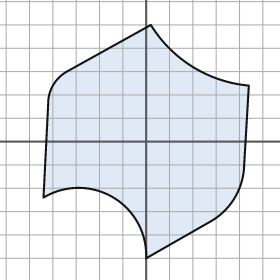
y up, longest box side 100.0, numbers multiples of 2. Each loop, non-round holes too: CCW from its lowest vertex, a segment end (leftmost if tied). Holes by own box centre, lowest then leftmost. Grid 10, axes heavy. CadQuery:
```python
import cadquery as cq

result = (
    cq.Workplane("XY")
    .moveTo(0.0, -50.0)
    .lineTo(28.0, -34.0)
    .threePointArc((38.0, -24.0), (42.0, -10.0))
    .lineTo(44.0, 24.0)
    .threePointArc((20.0, 32.0), (2.0, 50.0))
    .lineTo(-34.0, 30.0)
    .threePointArc((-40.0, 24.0), (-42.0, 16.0))
    .lineTo(-44.0, -24.0)
    .threePointArc((-14.0, -24.0), (0.0, -50.0))
    .close()
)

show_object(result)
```